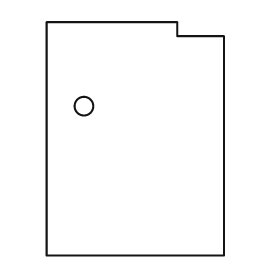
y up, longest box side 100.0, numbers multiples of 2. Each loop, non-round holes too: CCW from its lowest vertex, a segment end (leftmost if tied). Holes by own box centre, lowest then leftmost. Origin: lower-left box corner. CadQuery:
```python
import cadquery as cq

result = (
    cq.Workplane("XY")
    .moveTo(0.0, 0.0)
    .lineTo(76.0, 0.0)
    .lineTo(76.0, 94.0)
    .lineTo(56.0, 94.0)
    .lineTo(56.0, 100.0)
    .lineTo(0.0, 100.0)
    .close()
    .moveTo(16.0, 64.0)
    .circle(4.0)
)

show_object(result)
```